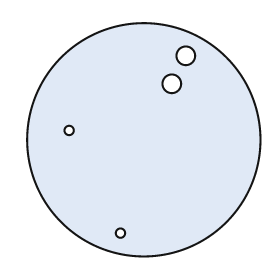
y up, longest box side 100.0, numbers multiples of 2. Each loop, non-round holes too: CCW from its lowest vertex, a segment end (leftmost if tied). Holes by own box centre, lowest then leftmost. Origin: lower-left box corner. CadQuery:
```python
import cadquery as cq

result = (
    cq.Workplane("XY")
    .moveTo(50.0, 50.0)
    .circle(50.0)
    .moveTo(40.0, 10.0)
    .circle(2.0)
    .moveTo(18.0, 54.0)
    .circle(2.0)
    .moveTo(62.0, 74.0)
    .circle(4.0)
    .moveTo(68.0, 86.0)
    .circle(4.0)
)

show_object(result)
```